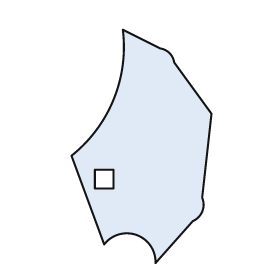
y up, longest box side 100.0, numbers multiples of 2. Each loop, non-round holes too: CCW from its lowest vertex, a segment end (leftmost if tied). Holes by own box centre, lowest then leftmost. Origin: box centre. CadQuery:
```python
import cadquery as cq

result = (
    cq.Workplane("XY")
    .moveTo(6.0, -50.0)
    .lineTo(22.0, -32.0)
    .threePointArc((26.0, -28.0), (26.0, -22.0))
    .lineTo(30.0, 14.0)
    .lineTo(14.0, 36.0)
    .threePointArc((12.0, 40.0), (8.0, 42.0))
    .lineTo(-8.0, 50.0)
    .threePointArc((-12.0, 20.0), (-30.0, -4.0))
    .lineTo(-16.0, -42.0)
    .threePointArc((-2.0, -38.0), (6.0, -50.0))
    .close()
    .moveTo(-20.0, -18.0)
    .lineTo(-12.0, -18.0)
    .lineTo(-12.0, -10.0)
    .lineTo(-20.0, -10.0)
    .close()
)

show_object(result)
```